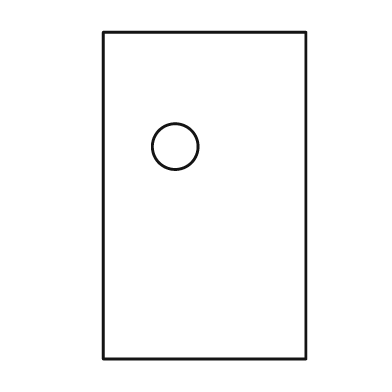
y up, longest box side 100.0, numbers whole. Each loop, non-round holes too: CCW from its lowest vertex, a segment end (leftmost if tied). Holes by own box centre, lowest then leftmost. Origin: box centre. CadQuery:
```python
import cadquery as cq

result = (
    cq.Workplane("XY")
    .moveTo(-31.0, -50.0)
    .lineTo(31.0, -50.0)
    .lineTo(31.0, 50.0)
    .lineTo(-31.0, 50.0)
    .close()
    .moveTo(-9.0, 15.0)
    .circle(7.0)
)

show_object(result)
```